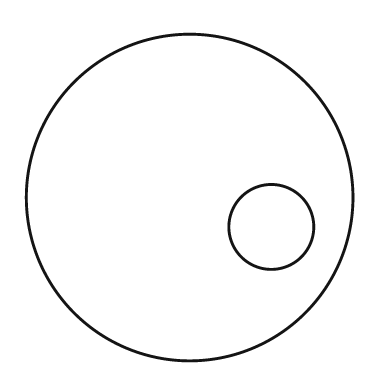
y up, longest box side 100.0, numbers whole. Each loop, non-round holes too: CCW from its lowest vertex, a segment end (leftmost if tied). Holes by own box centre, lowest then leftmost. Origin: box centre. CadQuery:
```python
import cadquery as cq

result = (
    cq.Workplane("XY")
    .moveTo(0.0, 0.0)
    .circle(50.0)
    .moveTo(25.0, -9.0)
    .circle(13.0)
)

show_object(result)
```